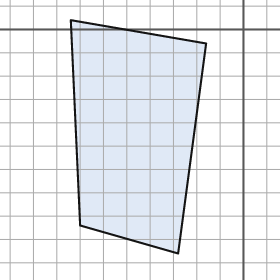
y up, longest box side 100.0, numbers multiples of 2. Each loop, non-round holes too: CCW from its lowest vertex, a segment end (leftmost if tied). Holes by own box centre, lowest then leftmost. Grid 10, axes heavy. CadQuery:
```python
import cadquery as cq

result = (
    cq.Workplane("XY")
    .moveTo(-28.0, -96.0)
    .lineTo(-16.0, -6.0)
    .lineTo(-74.0, 4.0)
    .lineTo(-70.0, -84.0)
    .close()
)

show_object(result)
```